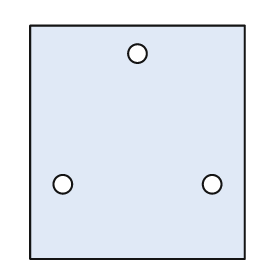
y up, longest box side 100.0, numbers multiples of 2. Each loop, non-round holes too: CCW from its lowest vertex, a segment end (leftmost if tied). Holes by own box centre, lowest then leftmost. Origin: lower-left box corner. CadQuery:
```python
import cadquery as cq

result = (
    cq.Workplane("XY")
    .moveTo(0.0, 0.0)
    .lineTo(92.0, 0.0)
    .lineTo(92.0, 100.0)
    .lineTo(0.0, 100.0)
    .close()
    .moveTo(14.0, 32.0)
    .circle(4.0)
    .moveTo(78.0, 32.0)
    .circle(4.0)
    .moveTo(46.0, 88.0)
    .circle(4.0)
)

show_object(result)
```